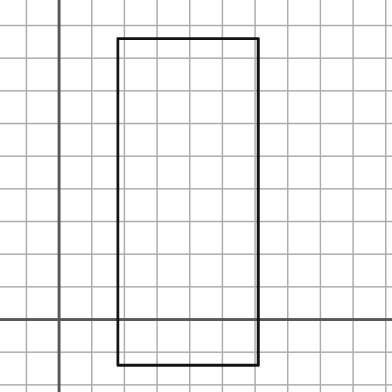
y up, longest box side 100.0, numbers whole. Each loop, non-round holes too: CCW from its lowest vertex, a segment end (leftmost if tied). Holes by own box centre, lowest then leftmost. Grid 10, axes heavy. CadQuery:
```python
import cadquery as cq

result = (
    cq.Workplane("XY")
    .moveTo(18.0, -14.0)
    .lineTo(61.0, -14.0)
    .lineTo(61.0, 86.0)
    .lineTo(18.0, 86.0)
    .close()
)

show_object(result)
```